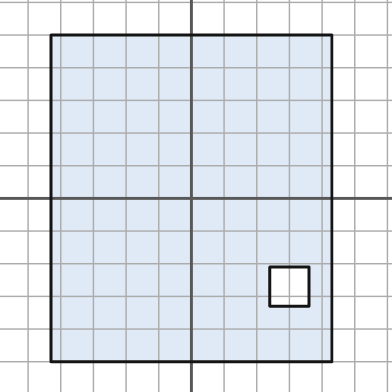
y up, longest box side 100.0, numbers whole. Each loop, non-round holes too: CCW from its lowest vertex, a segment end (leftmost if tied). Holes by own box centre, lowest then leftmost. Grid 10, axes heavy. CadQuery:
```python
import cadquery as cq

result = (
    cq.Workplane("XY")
    .moveTo(-43.0, -50.0)
    .lineTo(43.0, -50.0)
    .lineTo(43.0, 50.0)
    .lineTo(-43.0, 50.0)
    .close()
    .moveTo(24.0, -33.0)
    .lineTo(36.0, -33.0)
    .lineTo(36.0, -21.0)
    .lineTo(24.0, -21.0)
    .close()
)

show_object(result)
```